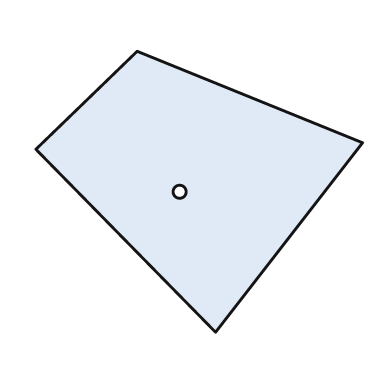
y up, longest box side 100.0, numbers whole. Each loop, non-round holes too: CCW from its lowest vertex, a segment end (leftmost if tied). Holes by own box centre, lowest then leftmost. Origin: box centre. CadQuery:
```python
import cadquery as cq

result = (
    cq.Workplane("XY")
    .moveTo(5.0, -43.0)
    .lineTo(50.0, 15.0)
    .lineTo(-19.0, 43.0)
    .lineTo(-50.0, 13.0)
    .close()
    .moveTo(-6.0, 0.0)
    .circle(2.0)
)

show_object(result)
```